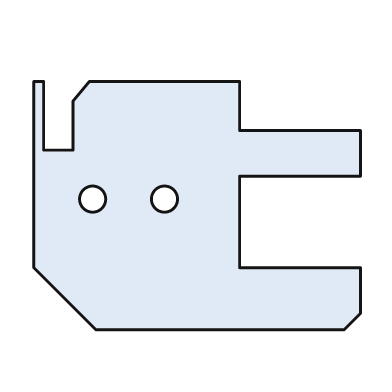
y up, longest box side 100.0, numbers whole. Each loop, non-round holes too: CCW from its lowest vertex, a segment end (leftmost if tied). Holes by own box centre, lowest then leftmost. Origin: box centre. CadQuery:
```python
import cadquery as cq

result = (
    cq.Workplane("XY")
    .moveTo(-31.0, -38.0)
    .lineTo(45.0, -38.0)
    .lineTo(50.0, -33.0)
    .lineTo(50.0, -19.0)
    .lineTo(13.0, -19.0)
    .lineTo(13.0, 9.0)
    .lineTo(50.0, 9.0)
    .lineTo(50.0, 23.0)
    .lineTo(13.0, 23.0)
    .lineTo(13.0, 38.0)
    .lineTo(-33.0, 38.0)
    .lineTo(-38.0, 32.0)
    .lineTo(-38.0, 17.0)
    .lineTo(-47.0, 17.0)
    .lineTo(-47.0, 38.0)
    .lineTo(-50.0, 38.0)
    .lineTo(-50.0, -19.0)
    .close()
    .moveTo(-32.0, 2.0)
    .circle(4.0)
    .moveTo(-10.0, 2.0)
    .circle(4.0)
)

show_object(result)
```